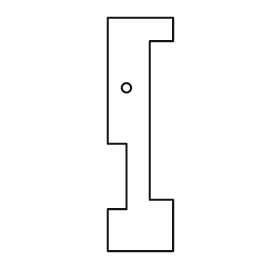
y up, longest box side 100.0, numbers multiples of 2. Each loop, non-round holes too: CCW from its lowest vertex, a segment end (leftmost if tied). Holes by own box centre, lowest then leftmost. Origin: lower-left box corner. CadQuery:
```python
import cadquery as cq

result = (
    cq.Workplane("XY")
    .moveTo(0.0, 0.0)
    .lineTo(28.0, 0.0)
    .lineTo(28.0, 22.0)
    .lineTo(18.0, 22.0)
    .lineTo(18.0, 90.0)
    .lineTo(28.0, 90.0)
    .lineTo(28.0, 100.0)
    .lineTo(0.0, 100.0)
    .lineTo(0.0, 46.0)
    .lineTo(8.0, 46.0)
    .lineTo(8.0, 18.0)
    .lineTo(0.0, 18.0)
    .close()
    .moveTo(8.0, 70.0)
    .circle(2.0)
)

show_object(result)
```